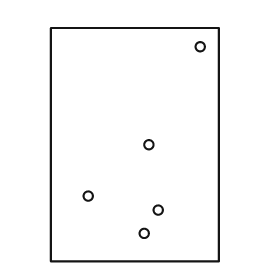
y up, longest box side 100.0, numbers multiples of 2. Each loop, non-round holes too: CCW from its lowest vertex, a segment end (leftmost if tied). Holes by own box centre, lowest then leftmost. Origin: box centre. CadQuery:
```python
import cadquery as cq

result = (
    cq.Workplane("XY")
    .moveTo(-36.0, -50.0)
    .lineTo(36.0, -50.0)
    .lineTo(36.0, 50.0)
    .lineTo(-36.0, 50.0)
    .close()
    .moveTo(4.0, -38.0)
    .circle(2.0)
    .moveTo(10.0, -28.0)
    .circle(2.0)
    .moveTo(-20.0, -22.0)
    .circle(2.0)
    .moveTo(6.0, 0.0)
    .circle(2.0)
    .moveTo(28.0, 42.0)
    .circle(2.0)
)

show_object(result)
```